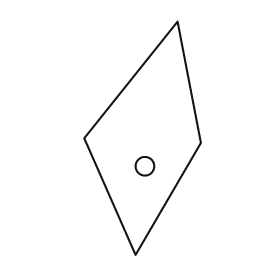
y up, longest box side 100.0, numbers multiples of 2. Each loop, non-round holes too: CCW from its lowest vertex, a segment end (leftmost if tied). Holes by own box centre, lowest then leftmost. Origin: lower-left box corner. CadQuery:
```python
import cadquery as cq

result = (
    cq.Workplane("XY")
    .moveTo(22.0, 0.0)
    .lineTo(50.0, 48.0)
    .lineTo(40.0, 100.0)
    .lineTo(0.0, 50.0)
    .close()
    .moveTo(26.0, 38.0)
    .circle(4.0)
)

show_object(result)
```